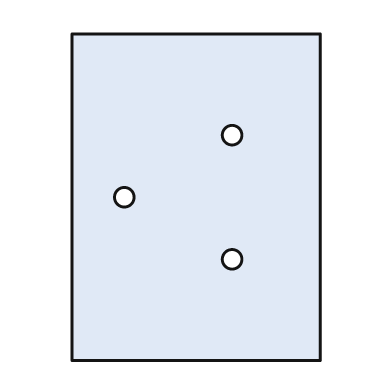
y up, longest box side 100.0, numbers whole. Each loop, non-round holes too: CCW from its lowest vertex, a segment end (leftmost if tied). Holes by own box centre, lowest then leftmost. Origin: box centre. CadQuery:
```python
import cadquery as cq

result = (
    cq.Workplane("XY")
    .moveTo(-38.0, -50.0)
    .lineTo(38.0, -50.0)
    .lineTo(38.0, 50.0)
    .lineTo(-38.0, 50.0)
    .close()
    .moveTo(11.0, -19.0)
    .circle(3.0)
    .moveTo(-22.0, 0.0)
    .circle(3.0)
    .moveTo(11.0, 19.0)
    .circle(3.0)
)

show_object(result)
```